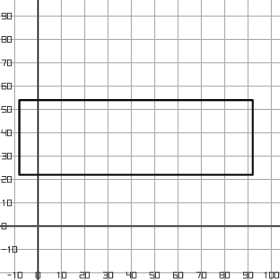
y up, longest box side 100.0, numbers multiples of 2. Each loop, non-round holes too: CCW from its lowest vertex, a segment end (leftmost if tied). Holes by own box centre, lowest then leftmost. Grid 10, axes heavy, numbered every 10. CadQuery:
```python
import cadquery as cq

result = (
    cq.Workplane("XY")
    .moveTo(-8.0, 22.0)
    .lineTo(92.0, 22.0)
    .lineTo(92.0, 54.0)
    .lineTo(-8.0, 54.0)
    .close()
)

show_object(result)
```